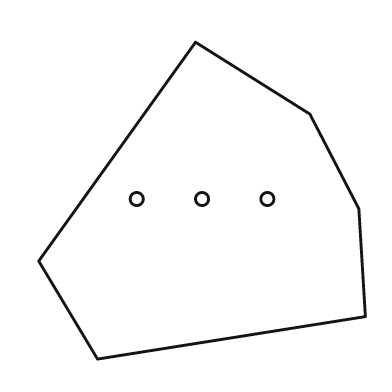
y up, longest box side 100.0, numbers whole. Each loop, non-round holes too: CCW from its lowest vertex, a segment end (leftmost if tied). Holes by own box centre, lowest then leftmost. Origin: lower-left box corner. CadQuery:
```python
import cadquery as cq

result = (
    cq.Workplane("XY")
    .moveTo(18.0, 0.0)
    .lineTo(100.0, 13.0)
    .lineTo(98.0, 46.0)
    .lineTo(83.0, 75.0)
    .lineTo(48.0, 97.0)
    .lineTo(0.0, 30.0)
    .close()
    .moveTo(30.0, 49.0)
    .circle(2.0)
    .moveTo(50.0, 49.0)
    .circle(2.0)
    .moveTo(70.0, 49.0)
    .circle(2.0)
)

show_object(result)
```